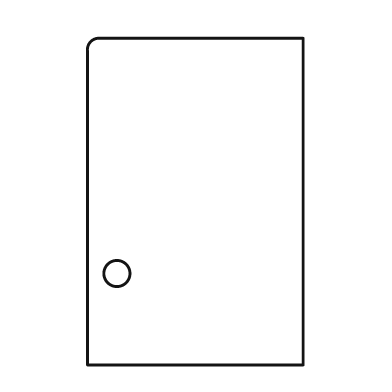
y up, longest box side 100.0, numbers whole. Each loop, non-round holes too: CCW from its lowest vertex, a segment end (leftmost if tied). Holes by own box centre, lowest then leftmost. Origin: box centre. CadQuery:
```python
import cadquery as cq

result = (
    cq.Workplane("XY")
    .moveTo(-33.0, -50.0)
    .lineTo(33.0, -50.0)
    .lineTo(33.0, 50.0)
    .lineTo(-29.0, 50.0)
    .threePointArc((-32.0, 49.0), (-33.0, 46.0))
    .close()
    .moveTo(-24.0, -22.0)
    .circle(4.0)
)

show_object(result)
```